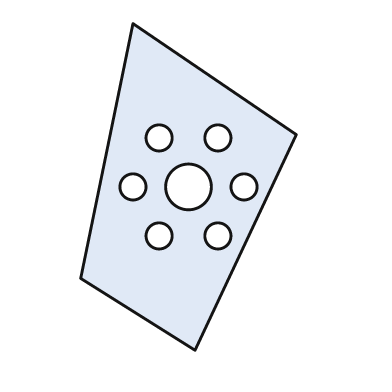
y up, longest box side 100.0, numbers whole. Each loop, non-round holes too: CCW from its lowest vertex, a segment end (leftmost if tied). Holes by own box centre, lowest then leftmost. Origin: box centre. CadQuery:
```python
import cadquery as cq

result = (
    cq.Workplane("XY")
    .moveTo(2.0, -50.0)
    .lineTo(33.0, 16.0)
    .lineTo(-17.0, 50.0)
    .lineTo(-33.0, -28.0)
    .close()
    .moveTo(-9.0, -15.0)
    .circle(4.0)
    .moveTo(9.0, -15.0)
    .circle(4.0)
    .moveTo(-17.0, 0.0)
    .circle(4.0)
    .moveTo(0.0, 0.0)
    .circle(7.0)
    .moveTo(17.0, 0.0)
    .circle(4.0)
    .moveTo(-9.0, 15.0)
    .circle(4.0)
    .moveTo(9.0, 15.0)
    .circle(4.0)
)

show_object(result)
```